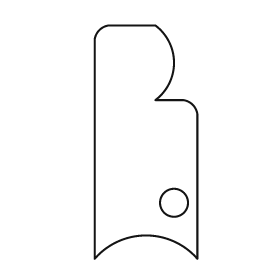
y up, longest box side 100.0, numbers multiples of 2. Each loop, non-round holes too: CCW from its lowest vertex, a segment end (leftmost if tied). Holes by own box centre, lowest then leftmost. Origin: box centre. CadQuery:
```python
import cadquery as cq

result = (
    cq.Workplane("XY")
    .moveTo(-22.0, -50.0)
    .threePointArc((0.0, -40.0), (22.0, -50.0))
    .lineTo(22.0, 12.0)
    .threePointArc((20.0, 16.0), (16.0, 18.0))
    .lineTo(4.0, 18.0)
    .threePointArc((12.0, 34.0), (4.0, 50.0))
    .lineTo(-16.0, 50.0)
    .threePointArc((-20.0, 48.0), (-22.0, 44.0))
    .close()
    .moveTo(12.0, -26.0)
    .circle(6.0)
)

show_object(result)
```